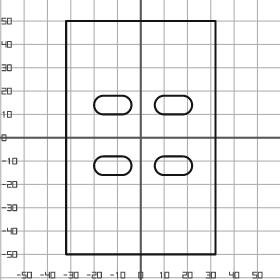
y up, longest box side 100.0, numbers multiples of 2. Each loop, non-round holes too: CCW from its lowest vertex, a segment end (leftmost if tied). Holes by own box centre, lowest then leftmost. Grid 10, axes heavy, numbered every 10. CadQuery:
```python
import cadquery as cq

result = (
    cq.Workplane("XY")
    .moveTo(-32.0, -50.0)
    .lineTo(32.0, -50.0)
    .lineTo(32.0, 50.0)
    .lineTo(-32.0, 50.0)
    .close()
    .moveTo(-16.0, -16.0)
    .lineTo(-8.0, -16.0)
    .threePointArc((-4.0, -12.0), (-8.0, -8.0))
    .lineTo(-16.0, -8.0)
    .threePointArc((-20.0, -12.0), (-16.0, -16.0))
    .close()
    .moveTo(10.0, -16.0)
    .lineTo(18.0, -16.0)
    .threePointArc((22.0, -12.0), (18.0, -8.0))
    .lineTo(10.0, -8.0)
    .threePointArc((6.0, -12.0), (10.0, -16.0))
    .close()
    .moveTo(-16.0, 10.0)
    .lineTo(-8.0, 10.0)
    .threePointArc((-4.0, 14.0), (-8.0, 18.0))
    .lineTo(-16.0, 18.0)
    .threePointArc((-20.0, 14.0), (-16.0, 10.0))
    .close()
    .moveTo(10.0, 10.0)
    .lineTo(18.0, 10.0)
    .threePointArc((22.0, 14.0), (18.0, 18.0))
    .lineTo(10.0, 18.0)
    .threePointArc((6.0, 14.0), (10.0, 10.0))
    .close()
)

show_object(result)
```